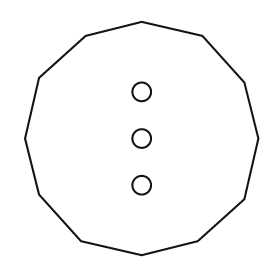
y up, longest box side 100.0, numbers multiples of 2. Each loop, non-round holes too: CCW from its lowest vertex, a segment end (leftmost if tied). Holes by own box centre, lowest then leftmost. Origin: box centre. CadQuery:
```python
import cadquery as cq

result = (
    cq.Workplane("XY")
    .moveTo(0.0, -50.0)
    .lineTo(24.0, -44.0)
    .lineTo(44.0, -26.0)
    .lineTo(50.0, 0.0)
    .lineTo(44.0, 24.0)
    .lineTo(26.0, 44.0)
    .lineTo(0.0, 50.0)
    .lineTo(-24.0, 44.0)
    .lineTo(-44.0, 26.0)
    .lineTo(-50.0, 0.0)
    .lineTo(-44.0, -24.0)
    .lineTo(-26.0, -44.0)
    .close()
    .moveTo(0.0, -20.0)
    .circle(4.0)
    .moveTo(0.0, 0.0)
    .circle(4.0)
    .moveTo(0.0, 20.0)
    .circle(4.0)
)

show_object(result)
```